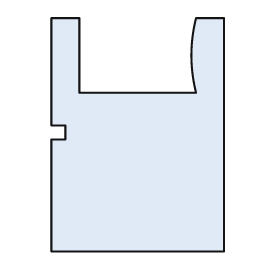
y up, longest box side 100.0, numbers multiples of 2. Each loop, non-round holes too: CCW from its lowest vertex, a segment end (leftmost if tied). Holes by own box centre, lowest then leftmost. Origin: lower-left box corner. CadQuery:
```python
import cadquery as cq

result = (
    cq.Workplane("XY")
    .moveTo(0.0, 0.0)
    .lineTo(74.0, 0.0)
    .lineTo(74.0, 100.0)
    .lineTo(62.0, 100.0)
    .threePointArc((60.0, 84.0), (62.0, 68.0))
    .lineTo(12.0, 68.0)
    .lineTo(12.0, 100.0)
    .lineTo(0.0, 100.0)
    .lineTo(0.0, 54.0)
    .lineTo(6.0, 54.0)
    .lineTo(6.0, 48.0)
    .lineTo(0.0, 48.0)
    .close()
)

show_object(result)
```